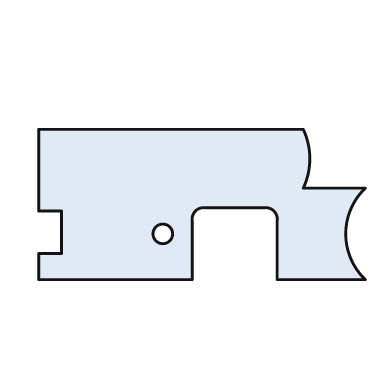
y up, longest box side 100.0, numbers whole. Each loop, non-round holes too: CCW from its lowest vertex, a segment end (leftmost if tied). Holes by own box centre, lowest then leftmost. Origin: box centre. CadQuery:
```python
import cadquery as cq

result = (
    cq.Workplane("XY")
    .moveTo(-50.0, -23.0)
    .lineTo(-3.0, -23.0)
    .lineTo(-3.0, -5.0)
    .threePointArc((-2.0, -2.0), (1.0, -1.0))
    .lineTo(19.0, -1.0)
    .threePointArc((22.0, -2.0), (23.0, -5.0))
    .lineTo(23.0, -23.0)
    .lineTo(50.0, -23.0)
    .threePointArc((44.0, -9.0), (50.0, 5.0))
    .lineTo(31.0, 5.0)
    .threePointArc((33.0, 14.0), (31.0, 23.0))
    .lineTo(-50.0, 23.0)
    .lineTo(-50.0, -2.0)
    .lineTo(-43.0, -2.0)
    .lineTo(-43.0, -15.0)
    .lineTo(-50.0, -15.0)
    .close()
    .moveTo(-12.0, -9.0)
    .circle(3.0)
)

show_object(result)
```